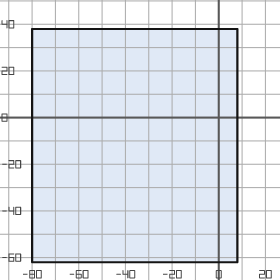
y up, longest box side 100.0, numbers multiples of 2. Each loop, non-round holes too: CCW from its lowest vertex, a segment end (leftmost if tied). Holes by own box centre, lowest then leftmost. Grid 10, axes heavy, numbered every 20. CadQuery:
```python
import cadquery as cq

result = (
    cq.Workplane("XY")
    .moveTo(-80.0, -62.0)
    .lineTo(8.0, -62.0)
    .lineTo(8.0, 38.0)
    .lineTo(-80.0, 38.0)
    .close()
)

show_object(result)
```